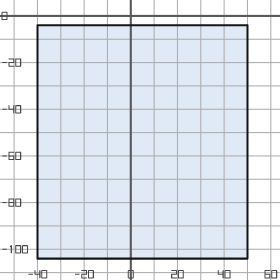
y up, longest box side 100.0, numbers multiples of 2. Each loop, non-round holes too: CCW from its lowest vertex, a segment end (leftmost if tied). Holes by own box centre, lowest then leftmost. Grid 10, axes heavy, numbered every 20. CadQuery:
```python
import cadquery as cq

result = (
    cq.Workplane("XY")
    .moveTo(-40.0, -104.0)
    .lineTo(50.0, -104.0)
    .lineTo(50.0, -4.0)
    .lineTo(-40.0, -4.0)
    .close()
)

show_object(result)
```